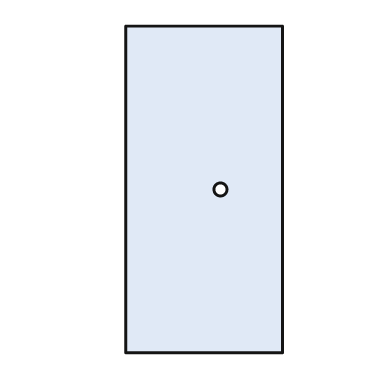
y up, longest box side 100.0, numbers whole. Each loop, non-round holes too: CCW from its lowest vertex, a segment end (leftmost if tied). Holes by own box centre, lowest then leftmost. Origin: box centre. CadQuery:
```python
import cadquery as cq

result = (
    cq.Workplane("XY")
    .moveTo(-24.0, -50.0)
    .lineTo(24.0, -50.0)
    .lineTo(24.0, 50.0)
    .lineTo(-24.0, 50.0)
    .close()
    .moveTo(5.0, 0.0)
    .circle(2.0)
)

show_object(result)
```